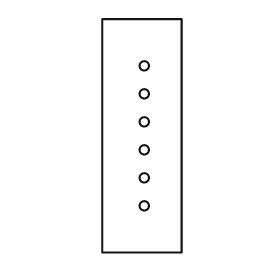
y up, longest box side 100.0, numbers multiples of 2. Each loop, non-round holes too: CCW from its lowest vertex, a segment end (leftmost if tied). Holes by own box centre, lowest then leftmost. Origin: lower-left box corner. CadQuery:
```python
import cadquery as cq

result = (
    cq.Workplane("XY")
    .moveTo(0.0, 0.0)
    .lineTo(34.0, 0.0)
    .lineTo(34.0, 100.0)
    .lineTo(0.0, 100.0)
    .close()
    .moveTo(18.0, 20.0)
    .circle(2.0)
    .moveTo(18.0, 32.0)
    .circle(2.0)
    .moveTo(18.0, 44.0)
    .circle(2.0)
    .moveTo(18.0, 56.0)
    .circle(2.0)
    .moveTo(18.0, 68.0)
    .circle(2.0)
    .moveTo(18.0, 80.0)
    .circle(2.0)
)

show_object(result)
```